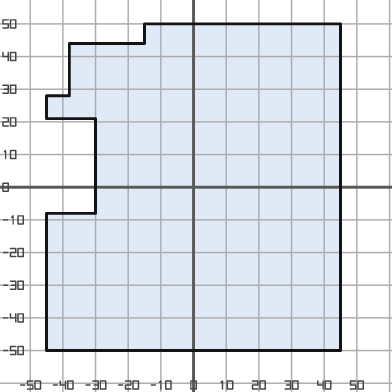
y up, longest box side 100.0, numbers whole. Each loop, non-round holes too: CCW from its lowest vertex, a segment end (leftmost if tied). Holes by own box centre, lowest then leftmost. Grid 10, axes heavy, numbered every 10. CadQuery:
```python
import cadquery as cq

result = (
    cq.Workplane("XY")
    .moveTo(-45.0, -50.0)
    .lineTo(45.0, -50.0)
    .lineTo(45.0, 50.0)
    .lineTo(-15.0, 50.0)
    .lineTo(-15.0, 44.0)
    .lineTo(-38.0, 44.0)
    .lineTo(-38.0, 28.0)
    .lineTo(-45.0, 28.0)
    .lineTo(-45.0, 21.0)
    .lineTo(-30.0, 21.0)
    .lineTo(-30.0, -8.0)
    .lineTo(-45.0, -8.0)
    .close()
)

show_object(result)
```